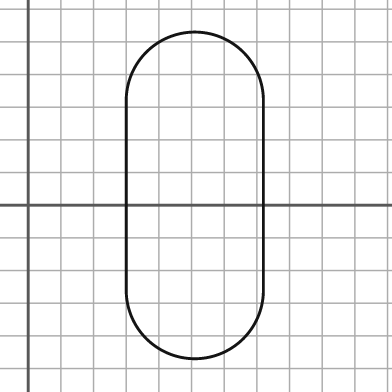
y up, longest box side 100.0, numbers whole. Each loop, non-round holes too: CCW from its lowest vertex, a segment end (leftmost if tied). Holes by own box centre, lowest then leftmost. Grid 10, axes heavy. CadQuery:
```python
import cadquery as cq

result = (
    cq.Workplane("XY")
    .moveTo(30.0, -26.0)
    .threePointArc((51.0, -47.0), (72.0, -26.0))
    .lineTo(72.0, 32.0)
    .threePointArc((51.0, 53.0), (30.0, 32.0))
    .close()
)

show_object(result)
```